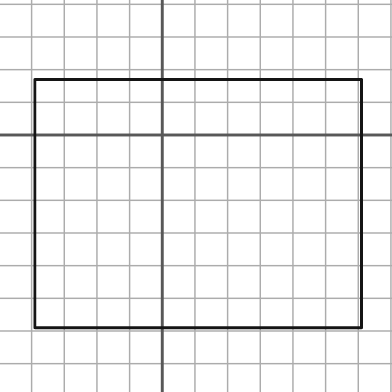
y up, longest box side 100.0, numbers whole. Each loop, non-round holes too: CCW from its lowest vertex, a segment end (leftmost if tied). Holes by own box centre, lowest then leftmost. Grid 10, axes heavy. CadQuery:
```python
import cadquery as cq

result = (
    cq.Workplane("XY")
    .moveTo(-39.0, -59.0)
    .lineTo(61.0, -59.0)
    .lineTo(61.0, 17.0)
    .lineTo(-39.0, 17.0)
    .close()
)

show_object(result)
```